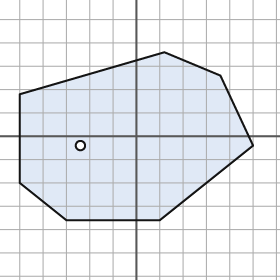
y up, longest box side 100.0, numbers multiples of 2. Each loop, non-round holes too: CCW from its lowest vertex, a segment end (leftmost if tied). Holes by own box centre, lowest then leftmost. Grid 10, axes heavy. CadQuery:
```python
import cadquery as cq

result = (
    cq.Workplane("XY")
    .moveTo(-30.0, -36.0)
    .lineTo(10.0, -36.0)
    .lineTo(50.0, -4.0)
    .lineTo(36.0, 26.0)
    .lineTo(12.0, 36.0)
    .lineTo(-50.0, 18.0)
    .lineTo(-50.0, -20.0)
    .close()
    .moveTo(-24.0, -4.0)
    .circle(2.0)
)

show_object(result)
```